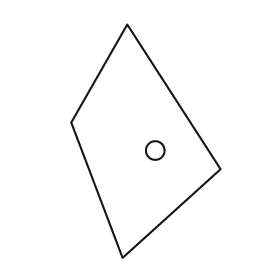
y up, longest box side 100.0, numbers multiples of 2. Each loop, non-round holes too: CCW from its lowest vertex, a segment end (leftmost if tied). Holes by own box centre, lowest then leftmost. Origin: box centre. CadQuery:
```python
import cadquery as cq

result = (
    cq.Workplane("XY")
    .moveTo(-10.0, -50.0)
    .lineTo(32.0, -12.0)
    .lineTo(-8.0, 50.0)
    .lineTo(-32.0, 8.0)
    .close()
    .moveTo(4.0, -4.0)
    .circle(4.0)
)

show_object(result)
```